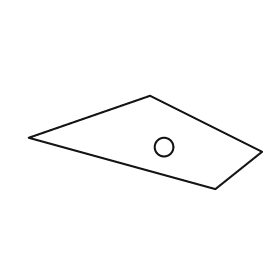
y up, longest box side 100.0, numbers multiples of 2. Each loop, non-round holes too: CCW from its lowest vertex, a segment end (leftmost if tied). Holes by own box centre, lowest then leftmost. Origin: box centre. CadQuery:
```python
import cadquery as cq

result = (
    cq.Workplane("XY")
    .moveTo(30.0, -20.0)
    .lineTo(50.0, -4.0)
    .lineTo(2.0, 20.0)
    .lineTo(-50.0, 2.0)
    .close()
    .moveTo(8.0, -2.0)
    .circle(4.0)
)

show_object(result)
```